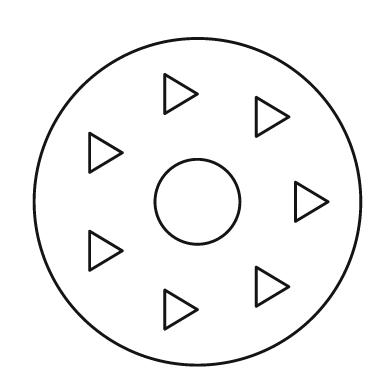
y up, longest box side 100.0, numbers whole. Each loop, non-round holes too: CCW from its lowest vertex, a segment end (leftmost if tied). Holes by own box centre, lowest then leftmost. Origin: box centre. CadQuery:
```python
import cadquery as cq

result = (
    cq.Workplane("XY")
    .moveTo(0.0, 0.0)
    .circle(50.0)
    .moveTo(-10.0, -39.0)
    .lineTo(0.0, -33.0)
    .lineTo(-10.0, -27.0)
    .close()
    .moveTo(18.0, -32.0)
    .lineTo(28.0, -26.0)
    .lineTo(18.0, -20.0)
    .close()
    .moveTo(-33.0, -21.0)
    .lineTo(-23.0, -15.0)
    .lineTo(-33.0, -9.0)
    .close()
    .moveTo(0.0, 0.0)
    .circle(13.0)
    .moveTo(30.0, -6.0)
    .lineTo(40.0, 0.0)
    .lineTo(30.0, 6.0)
    .close()
    .moveTo(-33.0, 9.0)
    .lineTo(-23.0, 15.0)
    .lineTo(-33.0, 21.0)
    .close()
    .moveTo(18.0, 20.0)
    .lineTo(28.0, 26.0)
    .lineTo(18.0, 32.0)
    .close()
    .moveTo(-10.0, 27.0)
    .lineTo(0.0, 33.0)
    .lineTo(-10.0, 39.0)
    .close()
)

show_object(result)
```